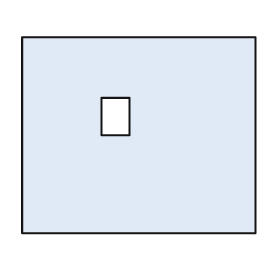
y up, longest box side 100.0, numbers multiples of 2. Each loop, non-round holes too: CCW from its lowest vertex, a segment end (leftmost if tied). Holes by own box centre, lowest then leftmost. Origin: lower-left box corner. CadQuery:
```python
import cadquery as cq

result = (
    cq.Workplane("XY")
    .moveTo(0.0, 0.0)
    .lineTo(100.0, 0.0)
    .lineTo(100.0, 84.0)
    .lineTo(0.0, 84.0)
    .close()
    .moveTo(34.0, 42.0)
    .lineTo(46.0, 42.0)
    .lineTo(46.0, 58.0)
    .lineTo(34.0, 58.0)
    .close()
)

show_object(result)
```